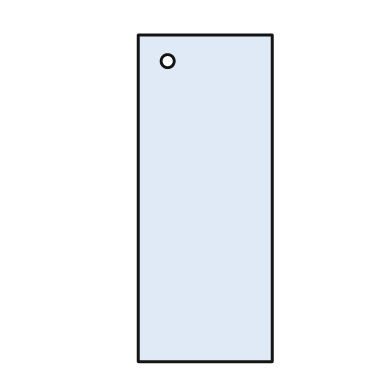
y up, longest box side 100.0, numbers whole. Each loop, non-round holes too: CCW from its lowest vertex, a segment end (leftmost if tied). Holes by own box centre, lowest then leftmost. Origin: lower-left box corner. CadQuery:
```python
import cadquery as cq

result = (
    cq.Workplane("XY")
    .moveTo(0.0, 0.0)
    .lineTo(41.0, 0.0)
    .lineTo(41.0, 100.0)
    .lineTo(0.0, 100.0)
    .close()
    .moveTo(9.0, 92.0)
    .circle(2.0)
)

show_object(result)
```